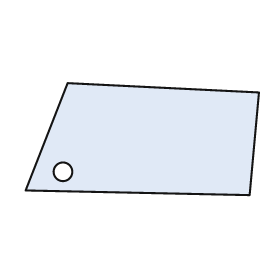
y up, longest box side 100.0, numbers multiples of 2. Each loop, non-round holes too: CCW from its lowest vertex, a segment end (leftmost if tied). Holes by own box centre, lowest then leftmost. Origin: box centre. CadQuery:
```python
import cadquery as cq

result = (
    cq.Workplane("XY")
    .moveTo(46.0, -24.0)
    .lineTo(50.0, 20.0)
    .lineTo(-32.0, 24.0)
    .lineTo(-50.0, -22.0)
    .close()
    .moveTo(-34.0, -14.0)
    .circle(4.0)
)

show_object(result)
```